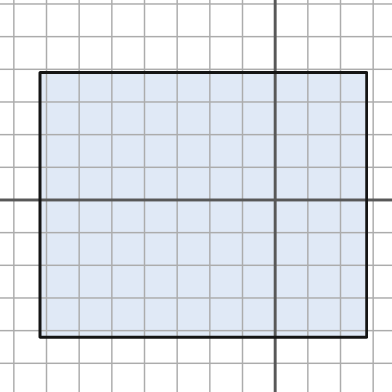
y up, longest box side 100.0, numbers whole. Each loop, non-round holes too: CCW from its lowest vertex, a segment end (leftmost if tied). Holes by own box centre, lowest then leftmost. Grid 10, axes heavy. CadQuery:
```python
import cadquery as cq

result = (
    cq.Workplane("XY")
    .moveTo(-72.0, -42.0)
    .lineTo(28.0, -42.0)
    .lineTo(28.0, 39.0)
    .lineTo(-72.0, 39.0)
    .close()
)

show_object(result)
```